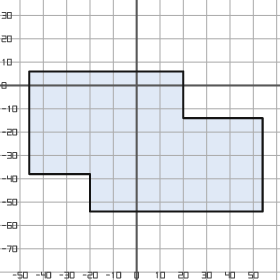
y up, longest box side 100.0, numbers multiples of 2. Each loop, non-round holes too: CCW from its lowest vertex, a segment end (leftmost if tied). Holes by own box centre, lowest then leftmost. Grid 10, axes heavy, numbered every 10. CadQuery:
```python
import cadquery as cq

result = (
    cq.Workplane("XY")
    .moveTo(-20.0, -54.0)
    .lineTo(54.0, -54.0)
    .lineTo(54.0, -14.0)
    .lineTo(20.0, -14.0)
    .lineTo(20.0, 6.0)
    .lineTo(-46.0, 6.0)
    .lineTo(-46.0, -38.0)
    .lineTo(-20.0, -38.0)
    .close()
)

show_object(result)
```